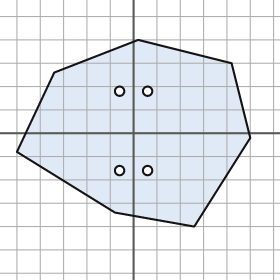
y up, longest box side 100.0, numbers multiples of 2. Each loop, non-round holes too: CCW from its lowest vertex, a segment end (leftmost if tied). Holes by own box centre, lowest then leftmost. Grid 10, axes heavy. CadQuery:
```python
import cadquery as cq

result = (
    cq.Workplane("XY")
    .moveTo(26.0, -40.0)
    .lineTo(50.0, -2.0)
    .lineTo(42.0, 30.0)
    .lineTo(2.0, 40.0)
    .lineTo(-34.0, 26.0)
    .lineTo(-50.0, -8.0)
    .lineTo(-8.0, -34.0)
    .close()
    .moveTo(-6.0, -16.0)
    .circle(2.0)
    .moveTo(6.0, -16.0)
    .circle(2.0)
    .moveTo(-6.0, 18.0)
    .circle(2.0)
    .moveTo(6.0, 18.0)
    .circle(2.0)
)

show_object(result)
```